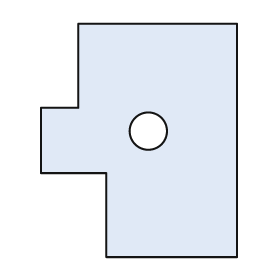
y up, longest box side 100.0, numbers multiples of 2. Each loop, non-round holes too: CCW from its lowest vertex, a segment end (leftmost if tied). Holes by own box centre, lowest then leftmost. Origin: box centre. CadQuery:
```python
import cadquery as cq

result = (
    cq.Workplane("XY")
    .moveTo(-14.0, -50.0)
    .lineTo(42.0, -50.0)
    .lineTo(42.0, 50.0)
    .lineTo(-26.0, 50.0)
    .lineTo(-26.0, 14.0)
    .lineTo(-42.0, 14.0)
    .lineTo(-42.0, -14.0)
    .lineTo(-14.0, -14.0)
    .close()
    .moveTo(4.0, 4.0)
    .circle(8.0)
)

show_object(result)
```